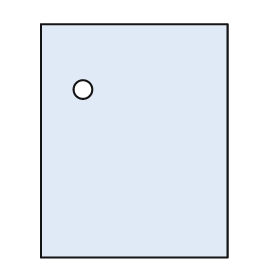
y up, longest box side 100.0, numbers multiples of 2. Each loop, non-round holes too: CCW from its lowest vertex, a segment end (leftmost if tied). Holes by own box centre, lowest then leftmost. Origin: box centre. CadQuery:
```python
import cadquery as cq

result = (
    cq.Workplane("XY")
    .moveTo(-40.0, -50.0)
    .lineTo(40.0, -50.0)
    .lineTo(40.0, 50.0)
    .lineTo(-40.0, 50.0)
    .close()
    .moveTo(-22.0, 22.0)
    .circle(4.0)
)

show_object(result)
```